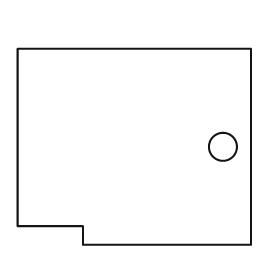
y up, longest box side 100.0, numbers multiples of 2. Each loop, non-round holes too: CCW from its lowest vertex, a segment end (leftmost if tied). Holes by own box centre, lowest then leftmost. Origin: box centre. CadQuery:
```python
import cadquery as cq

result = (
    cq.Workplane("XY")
    .moveTo(-22.0, -42.0)
    .lineTo(50.0, -42.0)
    .lineTo(50.0, 42.0)
    .lineTo(-50.0, 42.0)
    .lineTo(-50.0, -34.0)
    .lineTo(-22.0, -34.0)
    .close()
    .moveTo(38.0, 0.0)
    .circle(6.0)
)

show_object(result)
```